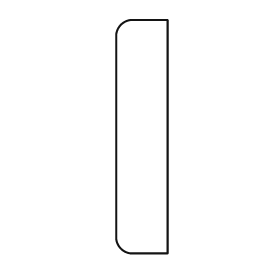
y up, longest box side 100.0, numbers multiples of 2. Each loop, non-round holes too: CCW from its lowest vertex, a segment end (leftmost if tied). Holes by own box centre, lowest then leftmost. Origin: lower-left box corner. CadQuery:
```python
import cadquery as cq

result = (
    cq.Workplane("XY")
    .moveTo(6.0, 0.0)
    .lineTo(22.0, 0.0)
    .lineTo(22.0, 100.0)
    .lineTo(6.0, 100.0)
    .threePointArc((2.0, 98.0), (0.0, 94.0))
    .lineTo(0.0, 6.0)
    .threePointArc((2.0, 2.0), (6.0, 0.0))
    .close()
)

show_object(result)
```